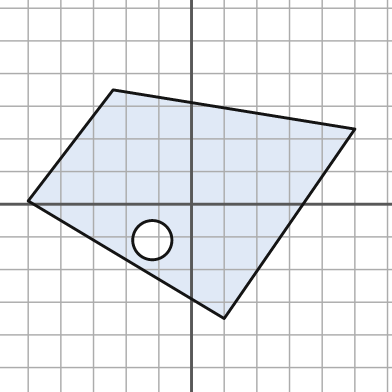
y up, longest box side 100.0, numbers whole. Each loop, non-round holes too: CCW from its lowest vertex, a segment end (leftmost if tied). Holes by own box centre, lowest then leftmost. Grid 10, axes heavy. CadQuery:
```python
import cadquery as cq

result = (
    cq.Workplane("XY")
    .moveTo(10.0, -35.0)
    .lineTo(50.0, 23.0)
    .lineTo(-24.0, 35.0)
    .lineTo(-50.0, 1.0)
    .close()
    .moveTo(-12.0, -11.0)
    .circle(6.0)
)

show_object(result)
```